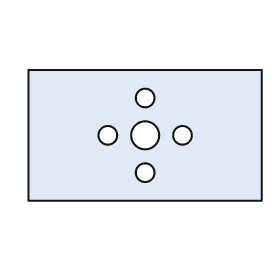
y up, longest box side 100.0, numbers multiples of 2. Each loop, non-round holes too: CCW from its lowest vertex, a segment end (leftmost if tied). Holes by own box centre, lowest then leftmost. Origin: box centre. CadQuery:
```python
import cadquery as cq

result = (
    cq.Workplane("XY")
    .moveTo(-50.0, -28.0)
    .lineTo(50.0, -28.0)
    .lineTo(50.0, 28.0)
    .lineTo(-50.0, 28.0)
    .close()
    .moveTo(0.0, -16.0)
    .circle(4.0)
    .moveTo(-16.0, 0.0)
    .circle(4.0)
    .moveTo(0.0, 0.0)
    .circle(6.0)
    .moveTo(16.0, 0.0)
    .circle(4.0)
    .moveTo(0.0, 16.0)
    .circle(4.0)
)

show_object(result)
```